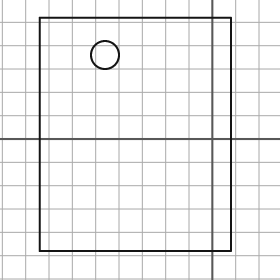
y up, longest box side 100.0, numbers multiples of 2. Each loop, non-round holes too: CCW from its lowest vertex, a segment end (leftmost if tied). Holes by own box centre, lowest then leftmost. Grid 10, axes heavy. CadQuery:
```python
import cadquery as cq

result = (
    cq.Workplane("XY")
    .moveTo(-74.0, -48.0)
    .lineTo(8.0, -48.0)
    .lineTo(8.0, 52.0)
    .lineTo(-74.0, 52.0)
    .close()
    .moveTo(-46.0, 36.0)
    .circle(6.0)
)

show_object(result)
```